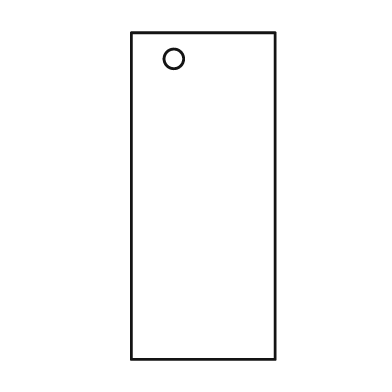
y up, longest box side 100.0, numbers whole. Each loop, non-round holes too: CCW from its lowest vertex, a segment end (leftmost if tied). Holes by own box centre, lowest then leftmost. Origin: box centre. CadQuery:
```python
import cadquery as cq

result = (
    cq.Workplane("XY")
    .moveTo(-22.0, -50.0)
    .lineTo(22.0, -50.0)
    .lineTo(22.0, 50.0)
    .lineTo(-22.0, 50.0)
    .close()
    .moveTo(-9.0, 42.0)
    .circle(3.0)
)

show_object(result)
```